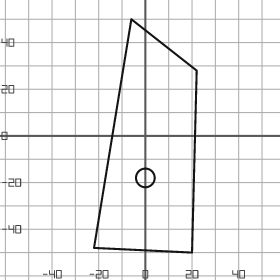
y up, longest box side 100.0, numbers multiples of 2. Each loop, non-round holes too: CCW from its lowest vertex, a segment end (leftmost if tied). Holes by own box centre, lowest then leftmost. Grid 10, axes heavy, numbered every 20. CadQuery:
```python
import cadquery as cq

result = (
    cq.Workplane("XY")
    .moveTo(20.0, -50.0)
    .lineTo(22.0, 28.0)
    .lineTo(-6.0, 50.0)
    .lineTo(-22.0, -48.0)
    .close()
    .moveTo(0.0, -18.0)
    .circle(4.0)
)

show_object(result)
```